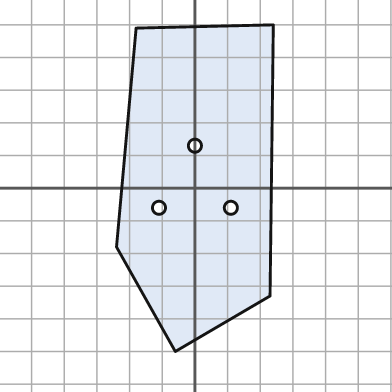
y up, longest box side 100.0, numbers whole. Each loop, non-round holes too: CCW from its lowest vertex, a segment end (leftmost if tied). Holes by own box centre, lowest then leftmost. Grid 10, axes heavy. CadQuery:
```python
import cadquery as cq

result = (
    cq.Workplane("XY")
    .moveTo(-6.0, -50.0)
    .lineTo(23.0, -33.0)
    .lineTo(24.0, 50.0)
    .lineTo(-18.0, 49.0)
    .lineTo(-24.0, -18.0)
    .close()
    .moveTo(-11.0, -6.0)
    .circle(2.0)
    .moveTo(11.0, -6.0)
    .circle(2.0)
    .moveTo(0.0, 13.0)
    .circle(2.0)
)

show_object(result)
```